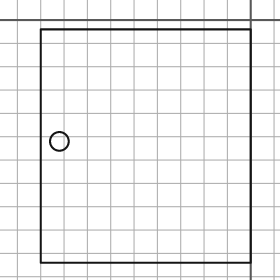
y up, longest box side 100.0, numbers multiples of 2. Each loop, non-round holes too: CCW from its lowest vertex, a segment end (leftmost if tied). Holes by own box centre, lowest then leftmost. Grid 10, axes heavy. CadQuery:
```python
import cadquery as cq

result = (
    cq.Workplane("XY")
    .moveTo(-90.0, -104.0)
    .lineTo(0.0, -104.0)
    .lineTo(0.0, -4.0)
    .lineTo(-90.0, -4.0)
    .close()
    .moveTo(-82.0, -52.0)
    .circle(4.0)
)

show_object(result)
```